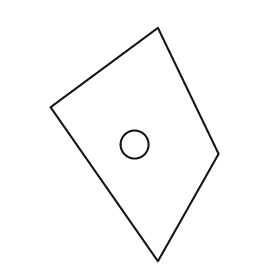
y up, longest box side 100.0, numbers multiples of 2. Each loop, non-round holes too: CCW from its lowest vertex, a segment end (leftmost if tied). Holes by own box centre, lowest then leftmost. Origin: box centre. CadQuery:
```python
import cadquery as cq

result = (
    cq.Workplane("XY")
    .moveTo(10.0, -50.0)
    .lineTo(36.0, -4.0)
    .lineTo(10.0, 50.0)
    .lineTo(-36.0, 16.0)
    .close()
    .moveTo(0.0, 0.0)
    .circle(6.0)
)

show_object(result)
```